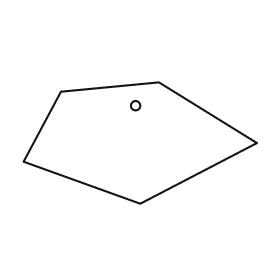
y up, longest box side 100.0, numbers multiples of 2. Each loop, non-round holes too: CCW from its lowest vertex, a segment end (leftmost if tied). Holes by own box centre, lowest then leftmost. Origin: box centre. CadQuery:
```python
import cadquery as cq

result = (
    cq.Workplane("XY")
    .moveTo(0.0, -26.0)
    .lineTo(50.0, 0.0)
    .lineTo(8.0, 26.0)
    .lineTo(-34.0, 22.0)
    .lineTo(-50.0, -8.0)
    .close()
    .moveTo(-2.0, 16.0)
    .circle(2.0)
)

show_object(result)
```